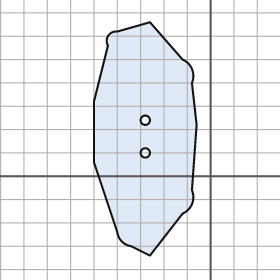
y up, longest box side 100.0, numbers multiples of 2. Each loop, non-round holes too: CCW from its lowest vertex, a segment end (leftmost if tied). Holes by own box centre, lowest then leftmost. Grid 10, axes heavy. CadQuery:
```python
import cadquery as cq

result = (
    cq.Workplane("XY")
    .moveTo(-26.0, -34.0)
    .lineTo(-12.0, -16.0)
    .threePointArc((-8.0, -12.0), (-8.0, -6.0))
    .lineTo(-6.0, 22.0)
    .lineTo(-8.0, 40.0)
    .threePointArc((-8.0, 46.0), (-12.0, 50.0))
    .lineTo(-26.0, 66.0)
    .lineTo(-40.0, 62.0)
    .threePointArc((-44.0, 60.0), (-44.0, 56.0))
    .lineTo(-50.0, 32.0)
    .lineTo(-50.0, 6.0)
    .lineTo(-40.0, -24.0)
    .threePointArc((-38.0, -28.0), (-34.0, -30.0))
    .close()
    .moveTo(-28.0, 10.0)
    .circle(2.0)
    .moveTo(-28.0, 24.0)
    .circle(2.0)
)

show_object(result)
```